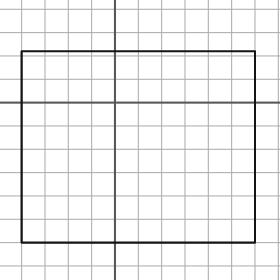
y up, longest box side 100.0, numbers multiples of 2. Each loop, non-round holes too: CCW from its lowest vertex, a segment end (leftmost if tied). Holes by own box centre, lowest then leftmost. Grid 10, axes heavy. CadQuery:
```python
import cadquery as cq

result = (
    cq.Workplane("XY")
    .moveTo(-40.0, -60.0)
    .lineTo(60.0, -60.0)
    .lineTo(60.0, 22.0)
    .lineTo(-40.0, 22.0)
    .close()
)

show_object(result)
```